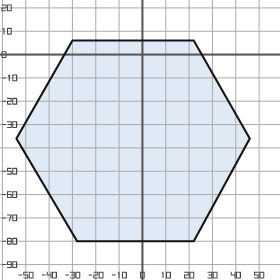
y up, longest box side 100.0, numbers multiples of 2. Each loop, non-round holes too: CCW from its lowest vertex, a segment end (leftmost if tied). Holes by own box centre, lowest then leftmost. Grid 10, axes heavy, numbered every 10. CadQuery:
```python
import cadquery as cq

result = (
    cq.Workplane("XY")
    .moveTo(-28.0, -80.0)
    .lineTo(22.0, -80.0)
    .lineTo(46.0, -36.0)
    .lineTo(22.0, 6.0)
    .lineTo(-30.0, 6.0)
    .lineTo(-54.0, -36.0)
    .close()
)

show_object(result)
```